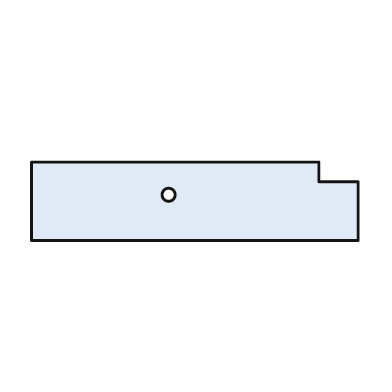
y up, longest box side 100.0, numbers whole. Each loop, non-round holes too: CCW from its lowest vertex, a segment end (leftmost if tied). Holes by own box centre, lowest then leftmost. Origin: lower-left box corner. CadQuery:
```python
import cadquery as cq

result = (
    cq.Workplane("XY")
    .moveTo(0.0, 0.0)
    .lineTo(100.0, 0.0)
    .lineTo(100.0, 18.0)
    .lineTo(88.0, 18.0)
    .lineTo(88.0, 24.0)
    .lineTo(0.0, 24.0)
    .close()
    .moveTo(42.0, 14.0)
    .circle(2.0)
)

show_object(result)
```